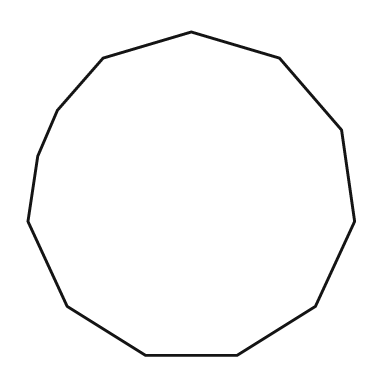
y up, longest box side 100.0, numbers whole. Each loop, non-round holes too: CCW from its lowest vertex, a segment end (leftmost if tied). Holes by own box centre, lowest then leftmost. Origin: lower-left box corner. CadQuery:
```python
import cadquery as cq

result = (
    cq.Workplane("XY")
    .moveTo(36.0, 0.0)
    .lineTo(64.0, 0.0)
    .lineTo(88.0, 15.0)
    .lineTo(100.0, 41.0)
    .lineTo(96.0, 69.0)
    .lineTo(77.0, 91.0)
    .lineTo(50.0, 99.0)
    .lineTo(23.0, 91.0)
    .lineTo(9.0, 75.0)
    .lineTo(3.0, 61.0)
    .lineTo(0.0, 41.0)
    .lineTo(12.0, 15.0)
    .close()
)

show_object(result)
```